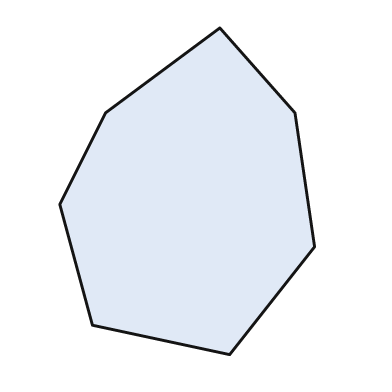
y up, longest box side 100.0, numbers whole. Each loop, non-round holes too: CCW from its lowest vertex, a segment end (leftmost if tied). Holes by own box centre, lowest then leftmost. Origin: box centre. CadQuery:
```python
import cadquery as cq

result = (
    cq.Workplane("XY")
    .moveTo(13.0, -50.0)
    .lineTo(39.0, -17.0)
    .lineTo(33.0, 24.0)
    .lineTo(10.0, 50.0)
    .lineTo(-25.0, 24.0)
    .lineTo(-39.0, -4.0)
    .lineTo(-29.0, -41.0)
    .close()
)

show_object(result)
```